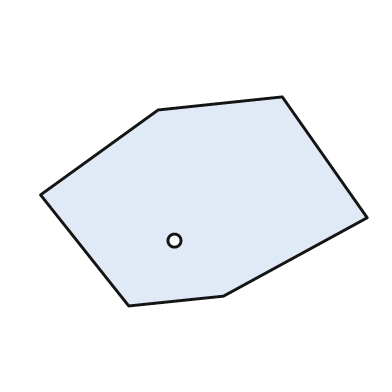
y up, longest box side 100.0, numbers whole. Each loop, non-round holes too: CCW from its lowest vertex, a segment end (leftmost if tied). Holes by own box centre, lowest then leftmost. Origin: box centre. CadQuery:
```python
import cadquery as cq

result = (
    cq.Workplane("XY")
    .moveTo(-23.0, -32.0)
    .lineTo(6.0, -29.0)
    .lineTo(50.0, -5.0)
    .lineTo(24.0, 32.0)
    .lineTo(-14.0, 28.0)
    .lineTo(-50.0, 2.0)
    .close()
    .moveTo(-9.0, -12.0)
    .circle(2.0)
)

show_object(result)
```